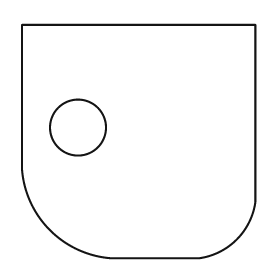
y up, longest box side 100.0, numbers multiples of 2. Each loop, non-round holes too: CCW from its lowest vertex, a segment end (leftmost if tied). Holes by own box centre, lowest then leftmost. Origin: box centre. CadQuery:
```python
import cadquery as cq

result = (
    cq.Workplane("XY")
    .moveTo(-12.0, -50.0)
    .lineTo(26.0, -50.0)
    .threePointArc((42.0, -42.0), (50.0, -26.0))
    .lineTo(50.0, 50.0)
    .lineTo(-50.0, 50.0)
    .lineTo(-50.0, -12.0)
    .threePointArc((-38.0, -38.0), (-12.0, -50.0))
    .close()
    .moveTo(-26.0, 6.0)
    .circle(12.0)
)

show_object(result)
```